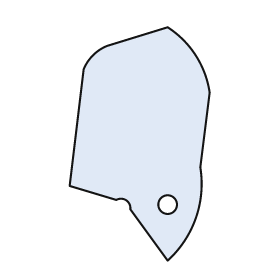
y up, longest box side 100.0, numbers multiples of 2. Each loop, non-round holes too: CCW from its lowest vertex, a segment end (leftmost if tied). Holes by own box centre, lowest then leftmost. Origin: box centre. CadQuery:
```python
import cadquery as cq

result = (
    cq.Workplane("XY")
    .moveTo(12.0, -50.0)
    .threePointArc((24.0, -32.0), (26.0, -10.0))
    .lineTo(30.0, 22.0)
    .threePointArc((24.0, 38.0), (12.0, 50.0))
    .lineTo(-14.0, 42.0)
    .threePointArc((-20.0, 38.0), (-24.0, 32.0))
    .lineTo(-30.0, -18.0)
    .lineTo(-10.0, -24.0)
    .threePointArc((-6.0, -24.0), (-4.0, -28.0))
    .close()
    .moveTo(12.0, -26.0)
    .circle(4.0)
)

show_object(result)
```